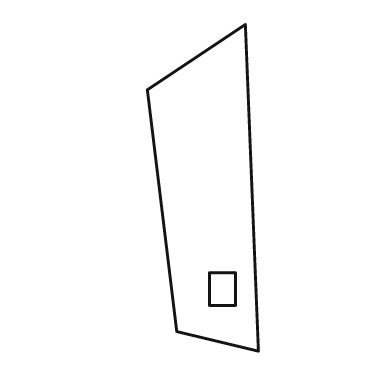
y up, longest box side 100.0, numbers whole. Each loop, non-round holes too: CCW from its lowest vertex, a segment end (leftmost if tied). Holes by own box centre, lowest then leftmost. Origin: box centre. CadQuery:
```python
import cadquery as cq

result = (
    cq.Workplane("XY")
    .moveTo(17.0, -50.0)
    .lineTo(13.0, 50.0)
    .lineTo(-17.0, 30.0)
    .lineTo(-8.0, -44.0)
    .close()
    .moveTo(2.0, -36.0)
    .lineTo(10.0, -36.0)
    .lineTo(10.0, -26.0)
    .lineTo(2.0, -26.0)
    .close()
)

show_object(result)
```